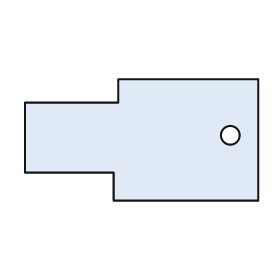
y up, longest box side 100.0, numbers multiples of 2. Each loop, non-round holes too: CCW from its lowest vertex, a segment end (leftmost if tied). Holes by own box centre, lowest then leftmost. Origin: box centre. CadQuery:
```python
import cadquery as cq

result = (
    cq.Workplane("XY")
    .moveTo(-12.0, -26.0)
    .lineTo(50.0, -26.0)
    .lineTo(50.0, 26.0)
    .lineTo(-10.0, 26.0)
    .lineTo(-10.0, 16.0)
    .lineTo(-50.0, 16.0)
    .lineTo(-50.0, -14.0)
    .lineTo(-12.0, -14.0)
    .close()
    .moveTo(38.0, 2.0)
    .circle(4.0)
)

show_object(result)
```